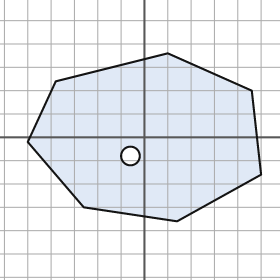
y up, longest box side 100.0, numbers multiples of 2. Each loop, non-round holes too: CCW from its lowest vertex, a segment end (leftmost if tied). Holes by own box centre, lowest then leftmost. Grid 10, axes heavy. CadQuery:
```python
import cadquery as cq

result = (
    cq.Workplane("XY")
    .moveTo(14.0, -36.0)
    .lineTo(50.0, -16.0)
    .lineTo(46.0, 20.0)
    .lineTo(10.0, 36.0)
    .lineTo(-38.0, 24.0)
    .lineTo(-50.0, -2.0)
    .lineTo(-26.0, -30.0)
    .close()
    .moveTo(-6.0, -8.0)
    .circle(4.0)
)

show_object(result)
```